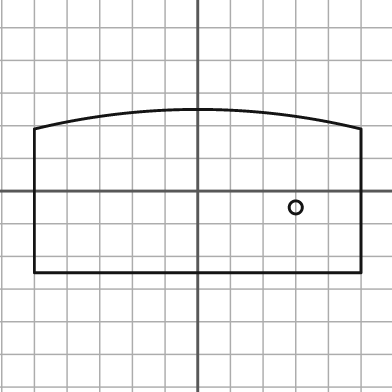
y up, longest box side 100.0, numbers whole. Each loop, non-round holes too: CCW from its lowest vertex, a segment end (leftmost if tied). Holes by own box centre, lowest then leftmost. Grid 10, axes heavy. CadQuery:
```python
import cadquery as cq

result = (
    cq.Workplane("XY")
    .moveTo(-50.0, -25.0)
    .lineTo(50.0, -25.0)
    .lineTo(50.0, 19.0)
    .threePointArc((0.0, 25.0), (-50.0, 19.0))
    .close()
    .moveTo(30.0, -5.0)
    .circle(2.0)
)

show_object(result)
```